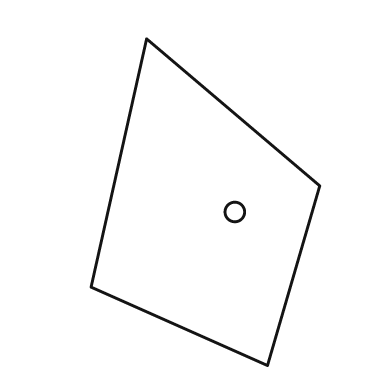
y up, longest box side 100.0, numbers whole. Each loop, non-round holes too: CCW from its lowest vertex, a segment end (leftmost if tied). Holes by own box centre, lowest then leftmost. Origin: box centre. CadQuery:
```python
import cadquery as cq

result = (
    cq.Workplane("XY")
    .moveTo(19.0, -50.0)
    .lineTo(35.0, 5.0)
    .lineTo(-18.0, 50.0)
    .lineTo(-35.0, -26.0)
    .close()
    .moveTo(9.0, -3.0)
    .circle(3.0)
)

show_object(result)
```